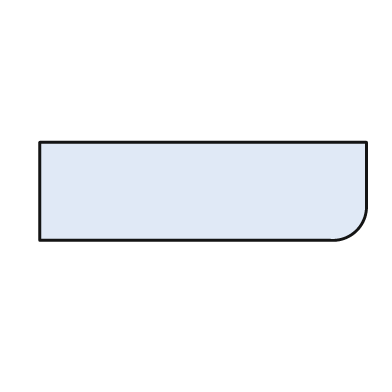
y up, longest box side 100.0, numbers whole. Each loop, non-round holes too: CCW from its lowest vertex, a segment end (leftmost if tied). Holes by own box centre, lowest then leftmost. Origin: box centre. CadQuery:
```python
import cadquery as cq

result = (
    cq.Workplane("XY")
    .moveTo(-50.0, -15.0)
    .lineTo(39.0, -15.0)
    .threePointArc((47.0, -12.0), (50.0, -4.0))
    .lineTo(50.0, 15.0)
    .lineTo(-50.0, 15.0)
    .close()
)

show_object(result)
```